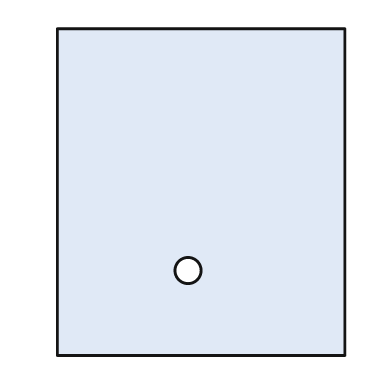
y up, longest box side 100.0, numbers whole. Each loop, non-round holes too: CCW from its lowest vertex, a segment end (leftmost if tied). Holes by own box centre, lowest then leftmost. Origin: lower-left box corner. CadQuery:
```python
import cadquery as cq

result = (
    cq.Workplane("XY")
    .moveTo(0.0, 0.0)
    .lineTo(88.0, 0.0)
    .lineTo(88.0, 100.0)
    .lineTo(0.0, 100.0)
    .close()
    .moveTo(40.0, 26.0)
    .circle(4.0)
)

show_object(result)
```